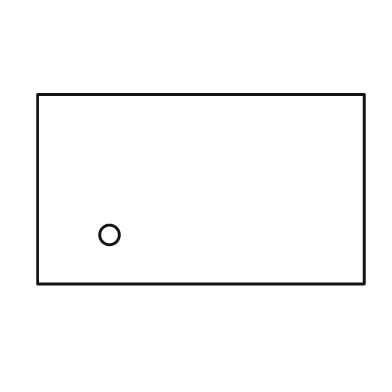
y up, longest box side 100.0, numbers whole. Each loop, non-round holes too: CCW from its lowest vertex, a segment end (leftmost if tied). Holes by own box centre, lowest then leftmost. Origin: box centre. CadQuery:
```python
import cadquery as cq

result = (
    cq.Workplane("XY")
    .moveTo(-50.0, -29.0)
    .lineTo(50.0, -29.0)
    .lineTo(50.0, 29.0)
    .lineTo(-50.0, 29.0)
    .close()
    .moveTo(-28.0, -14.0)
    .circle(3.0)
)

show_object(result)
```